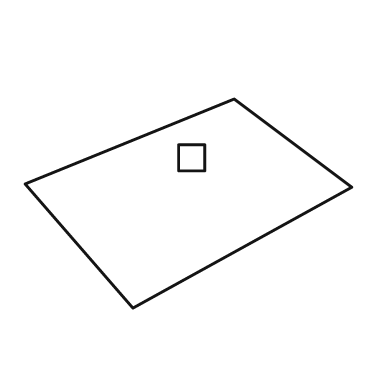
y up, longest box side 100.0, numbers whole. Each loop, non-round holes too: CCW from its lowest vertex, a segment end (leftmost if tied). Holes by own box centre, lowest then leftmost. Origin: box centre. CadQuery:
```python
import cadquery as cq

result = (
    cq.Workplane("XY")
    .moveTo(-17.0, -32.0)
    .lineTo(50.0, 5.0)
    .lineTo(14.0, 32.0)
    .lineTo(-50.0, 6.0)
    .close()
    .moveTo(-3.0, 10.0)
    .lineTo(5.0, 10.0)
    .lineTo(5.0, 18.0)
    .lineTo(-3.0, 18.0)
    .close()
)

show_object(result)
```